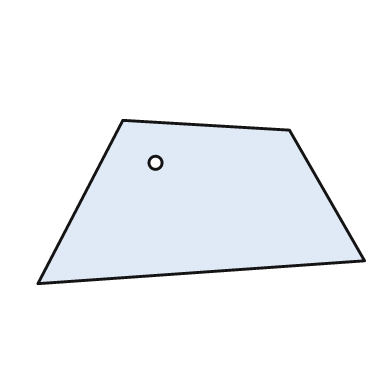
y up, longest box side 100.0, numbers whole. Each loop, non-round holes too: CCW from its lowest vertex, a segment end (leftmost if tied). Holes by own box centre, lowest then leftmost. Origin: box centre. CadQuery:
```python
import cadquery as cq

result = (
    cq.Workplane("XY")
    .moveTo(-50.0, -25.0)
    .lineTo(50.0, -18.0)
    .lineTo(27.0, 22.0)
    .lineTo(-24.0, 25.0)
    .close()
    .moveTo(-14.0, 12.0)
    .circle(2.0)
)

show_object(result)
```